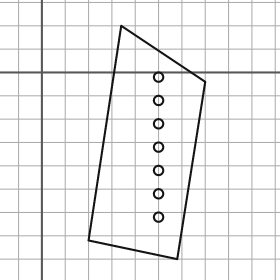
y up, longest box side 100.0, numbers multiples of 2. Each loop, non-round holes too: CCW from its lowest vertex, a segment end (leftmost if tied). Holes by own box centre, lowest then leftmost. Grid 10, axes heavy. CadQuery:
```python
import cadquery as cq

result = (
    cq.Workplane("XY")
    .moveTo(58.0, -80.0)
    .lineTo(70.0, -4.0)
    .lineTo(34.0, 20.0)
    .lineTo(20.0, -72.0)
    .close()
    .moveTo(50.0, -62.0)
    .circle(2.0)
    .moveTo(50.0, -52.0)
    .circle(2.0)
    .moveTo(50.0, -42.0)
    .circle(2.0)
    .moveTo(50.0, -32.0)
    .circle(2.0)
    .moveTo(50.0, -22.0)
    .circle(2.0)
    .moveTo(50.0, -12.0)
    .circle(2.0)
    .moveTo(50.0, -2.0)
    .circle(2.0)
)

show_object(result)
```